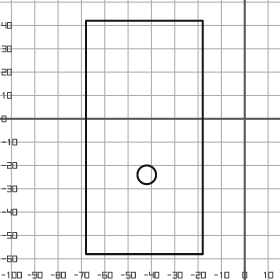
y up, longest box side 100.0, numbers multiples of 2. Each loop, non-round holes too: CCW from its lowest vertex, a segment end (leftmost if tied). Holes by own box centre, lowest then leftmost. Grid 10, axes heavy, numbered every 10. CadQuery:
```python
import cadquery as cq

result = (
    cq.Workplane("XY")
    .moveTo(-68.0, -58.0)
    .lineTo(-18.0, -58.0)
    .lineTo(-18.0, 42.0)
    .lineTo(-68.0, 42.0)
    .close()
    .moveTo(-42.0, -24.0)
    .circle(4.0)
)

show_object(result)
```